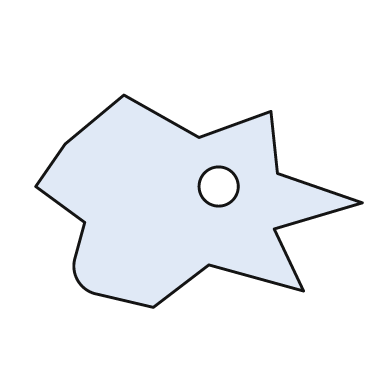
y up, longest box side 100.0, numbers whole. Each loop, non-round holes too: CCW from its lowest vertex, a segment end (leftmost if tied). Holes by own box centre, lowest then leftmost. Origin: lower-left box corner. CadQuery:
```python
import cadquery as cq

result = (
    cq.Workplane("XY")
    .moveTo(36.0, 0.0)
    .lineTo(53.0, 13.0)
    .lineTo(82.0, 5.0)
    .lineTo(73.0, 24.0)
    .lineTo(100.0, 32.0)
    .lineTo(74.0, 41.0)
    .lineTo(72.0, 60.0)
    .lineTo(50.0, 52.0)
    .lineTo(27.0, 65.0)
    .lineTo(9.0, 50.0)
    .lineTo(0.0, 37.0)
    .lineTo(15.0, 26.0)
    .lineTo(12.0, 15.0)
    .threePointArc((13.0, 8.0), (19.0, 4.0))
    .close()
    .moveTo(56.0, 37.0)
    .circle(6.0)
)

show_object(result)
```